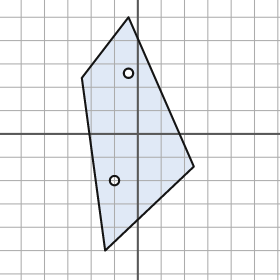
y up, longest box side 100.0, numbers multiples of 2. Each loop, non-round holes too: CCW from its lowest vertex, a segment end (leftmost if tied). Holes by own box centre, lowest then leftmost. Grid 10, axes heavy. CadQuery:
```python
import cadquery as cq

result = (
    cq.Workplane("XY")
    .moveTo(-14.0, -50.0)
    .lineTo(24.0, -14.0)
    .lineTo(-4.0, 50.0)
    .lineTo(-24.0, 24.0)
    .close()
    .moveTo(-10.0, -20.0)
    .circle(2.0)
    .moveTo(-4.0, 26.0)
    .circle(2.0)
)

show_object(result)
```